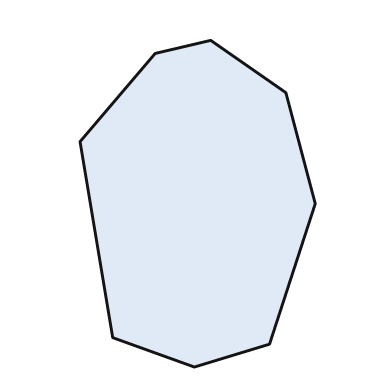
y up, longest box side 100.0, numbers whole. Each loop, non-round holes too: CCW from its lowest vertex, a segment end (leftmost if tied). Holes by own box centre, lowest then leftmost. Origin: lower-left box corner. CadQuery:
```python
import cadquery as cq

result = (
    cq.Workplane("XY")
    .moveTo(35.0, 0.0)
    .lineTo(58.0, 7.0)
    .lineTo(72.0, 50.0)
    .lineTo(63.0, 84.0)
    .lineTo(40.0, 100.0)
    .lineTo(23.0, 96.0)
    .lineTo(0.0, 69.0)
    .lineTo(10.0, 9.0)
    .close()
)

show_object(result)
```